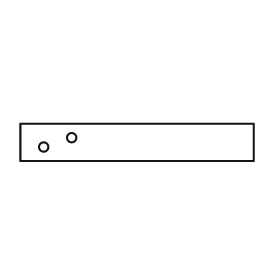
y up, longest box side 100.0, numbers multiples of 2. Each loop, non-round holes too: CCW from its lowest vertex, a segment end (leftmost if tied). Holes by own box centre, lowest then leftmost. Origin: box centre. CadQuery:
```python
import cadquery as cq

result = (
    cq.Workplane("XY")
    .moveTo(-50.0, -8.0)
    .lineTo(50.0, -8.0)
    .lineTo(50.0, 8.0)
    .lineTo(-50.0, 8.0)
    .close()
    .moveTo(-40.0, -2.0)
    .circle(2.0)
    .moveTo(-28.0, 2.0)
    .circle(2.0)
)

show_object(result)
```